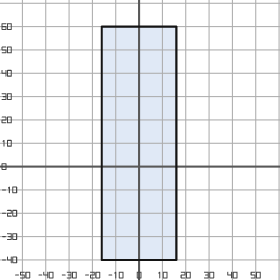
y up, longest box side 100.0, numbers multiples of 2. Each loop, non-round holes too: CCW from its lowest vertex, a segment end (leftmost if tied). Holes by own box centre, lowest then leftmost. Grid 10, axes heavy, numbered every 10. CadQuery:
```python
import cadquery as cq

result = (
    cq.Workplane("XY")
    .moveTo(-16.0, -40.0)
    .lineTo(16.0, -40.0)
    .lineTo(16.0, 60.0)
    .lineTo(-16.0, 60.0)
    .close()
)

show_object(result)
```